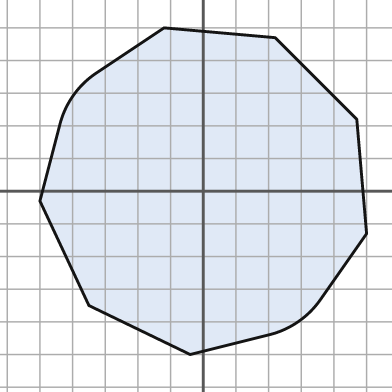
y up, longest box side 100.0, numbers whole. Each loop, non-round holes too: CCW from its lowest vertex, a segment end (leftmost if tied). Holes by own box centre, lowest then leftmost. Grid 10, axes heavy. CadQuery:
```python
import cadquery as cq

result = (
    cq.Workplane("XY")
    .moveTo(-4.0, -50.0)
    .lineTo(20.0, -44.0)
    .threePointArc((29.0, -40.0), (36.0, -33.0))
    .lineTo(50.0, -13.0)
    .lineTo(47.0, 22.0)
    .lineTo(22.0, 47.0)
    .lineTo(-12.0, 50.0)
    .lineTo(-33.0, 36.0)
    .threePointArc((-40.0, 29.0), (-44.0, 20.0))
    .lineTo(-50.0, -3.0)
    .lineTo(-35.0, -35.0)
    .close()
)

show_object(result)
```